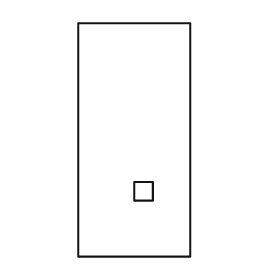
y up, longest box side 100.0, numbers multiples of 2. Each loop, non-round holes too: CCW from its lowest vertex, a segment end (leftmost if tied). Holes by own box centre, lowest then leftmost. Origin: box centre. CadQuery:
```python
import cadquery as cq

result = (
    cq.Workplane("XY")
    .moveTo(-24.0, -50.0)
    .lineTo(24.0, -50.0)
    .lineTo(24.0, 50.0)
    .lineTo(-24.0, 50.0)
    .close()
    .moveTo(0.0, -26.0)
    .lineTo(8.0, -26.0)
    .lineTo(8.0, -18.0)
    .lineTo(0.0, -18.0)
    .close()
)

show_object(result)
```